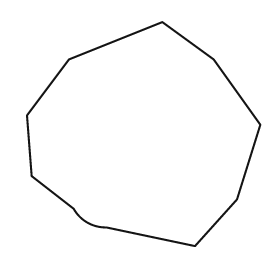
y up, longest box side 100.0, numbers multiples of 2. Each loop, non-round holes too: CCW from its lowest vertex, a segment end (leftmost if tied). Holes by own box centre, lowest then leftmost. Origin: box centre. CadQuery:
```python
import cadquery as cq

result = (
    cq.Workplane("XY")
    .moveTo(22.0, -48.0)
    .lineTo(40.0, -28.0)
    .lineTo(50.0, 4.0)
    .lineTo(30.0, 32.0)
    .lineTo(8.0, 48.0)
    .lineTo(-32.0, 32.0)
    .lineTo(-50.0, 8.0)
    .lineTo(-48.0, -18.0)
    .lineTo(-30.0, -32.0)
    .threePointArc((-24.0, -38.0), (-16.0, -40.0))
    .close()
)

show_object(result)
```